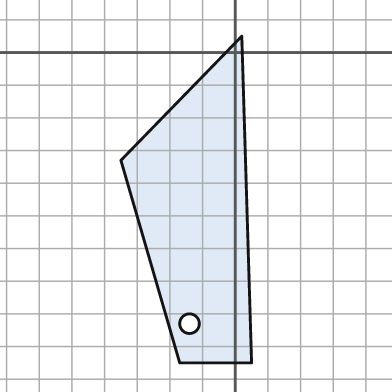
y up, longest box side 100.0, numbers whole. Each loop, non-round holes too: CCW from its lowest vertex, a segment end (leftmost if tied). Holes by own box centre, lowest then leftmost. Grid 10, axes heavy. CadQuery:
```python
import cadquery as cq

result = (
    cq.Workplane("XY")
    .moveTo(-17.0, -95.0)
    .lineTo(5.0, -95.0)
    .lineTo(2.0, 5.0)
    .lineTo(-35.0, -33.0)
    .close()
    .moveTo(-14.0, -83.0)
    .circle(3.0)
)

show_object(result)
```